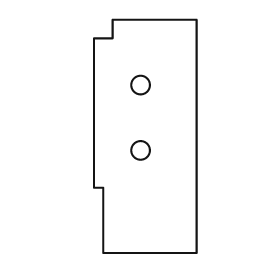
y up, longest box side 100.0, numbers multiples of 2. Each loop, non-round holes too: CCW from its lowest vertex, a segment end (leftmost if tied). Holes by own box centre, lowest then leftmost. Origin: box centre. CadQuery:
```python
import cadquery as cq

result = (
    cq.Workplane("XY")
    .moveTo(-18.0, -50.0)
    .lineTo(22.0, -50.0)
    .lineTo(22.0, 50.0)
    .lineTo(-14.0, 50.0)
    .lineTo(-14.0, 42.0)
    .lineTo(-22.0, 42.0)
    .lineTo(-22.0, -22.0)
    .lineTo(-18.0, -22.0)
    .close()
    .moveTo(-2.0, -6.0)
    .circle(4.0)
    .moveTo(-2.0, 22.0)
    .circle(4.0)
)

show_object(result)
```